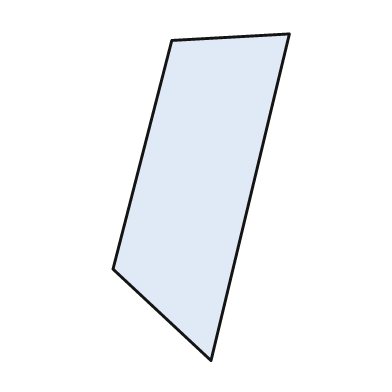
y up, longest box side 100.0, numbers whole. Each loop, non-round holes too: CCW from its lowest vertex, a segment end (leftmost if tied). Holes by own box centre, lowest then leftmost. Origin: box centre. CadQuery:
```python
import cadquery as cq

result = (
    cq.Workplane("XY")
    .moveTo(3.0, -50.0)
    .lineTo(27.0, 50.0)
    .lineTo(-9.0, 48.0)
    .lineTo(-27.0, -22.0)
    .close()
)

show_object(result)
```